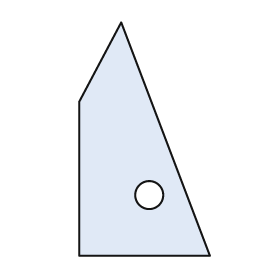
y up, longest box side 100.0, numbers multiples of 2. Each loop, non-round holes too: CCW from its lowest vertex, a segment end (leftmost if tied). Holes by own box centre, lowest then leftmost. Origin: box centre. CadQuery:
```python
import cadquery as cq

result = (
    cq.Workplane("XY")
    .moveTo(-28.0, -50.0)
    .lineTo(28.0, -50.0)
    .lineTo(-10.0, 50.0)
    .lineTo(-28.0, 16.0)
    .close()
    .moveTo(2.0, -24.0)
    .circle(6.0)
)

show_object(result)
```